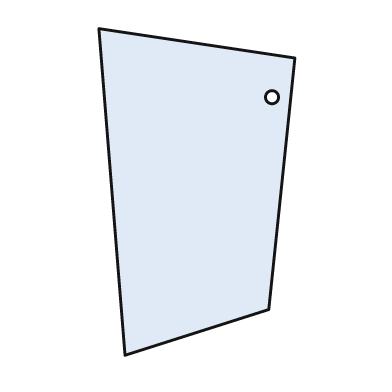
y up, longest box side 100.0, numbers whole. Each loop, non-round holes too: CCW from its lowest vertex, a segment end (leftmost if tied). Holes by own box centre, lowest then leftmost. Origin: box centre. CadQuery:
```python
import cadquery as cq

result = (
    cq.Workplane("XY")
    .moveTo(-22.0, -50.0)
    .lineTo(22.0, -36.0)
    .lineTo(30.0, 41.0)
    .lineTo(-30.0, 50.0)
    .close()
    .moveTo(23.0, 29.0)
    .circle(2.0)
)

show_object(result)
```